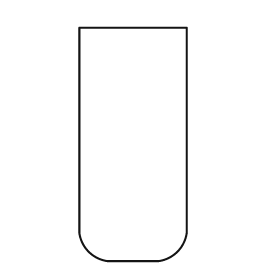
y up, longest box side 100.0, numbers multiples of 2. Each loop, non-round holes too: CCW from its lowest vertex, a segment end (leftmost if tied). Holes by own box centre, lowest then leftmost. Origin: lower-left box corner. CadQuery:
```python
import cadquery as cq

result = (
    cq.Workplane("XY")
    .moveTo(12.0, 0.0)
    .lineTo(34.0, 0.0)
    .threePointArc((42.0, 4.0), (46.0, 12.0))
    .lineTo(46.0, 100.0)
    .lineTo(0.0, 100.0)
    .lineTo(0.0, 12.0)
    .threePointArc((4.0, 4.0), (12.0, 0.0))
    .close()
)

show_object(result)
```